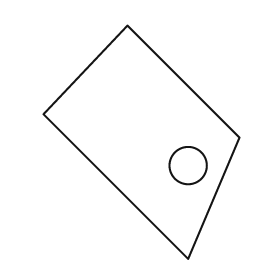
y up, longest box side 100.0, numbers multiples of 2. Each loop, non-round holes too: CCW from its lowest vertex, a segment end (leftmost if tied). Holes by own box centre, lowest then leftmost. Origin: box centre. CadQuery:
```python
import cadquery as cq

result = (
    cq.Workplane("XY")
    .moveTo(20.0, -50.0)
    .lineTo(42.0, 2.0)
    .lineTo(-6.0, 50.0)
    .lineTo(-42.0, 12.0)
    .close()
    .moveTo(20.0, -10.0)
    .circle(8.0)
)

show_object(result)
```